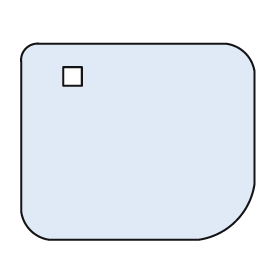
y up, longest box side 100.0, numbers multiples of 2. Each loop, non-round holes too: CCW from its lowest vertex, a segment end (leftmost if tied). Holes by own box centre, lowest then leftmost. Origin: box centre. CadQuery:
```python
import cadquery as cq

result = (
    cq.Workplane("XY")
    .moveTo(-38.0, -42.0)
    .lineTo(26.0, -42.0)
    .threePointArc((42.0, -34.0), (50.0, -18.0))
    .lineTo(50.0, 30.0)
    .threePointArc((46.0, 38.0), (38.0, 42.0))
    .lineTo(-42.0, 42.0)
    .threePointArc((-48.0, 40.0), (-50.0, 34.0))
    .lineTo(-50.0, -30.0)
    .threePointArc((-46.0, -38.0), (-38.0, -42.0))
    .close()
    .moveTo(-32.0, 24.0)
    .lineTo(-24.0, 24.0)
    .lineTo(-24.0, 32.0)
    .lineTo(-32.0, 32.0)
    .close()
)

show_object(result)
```